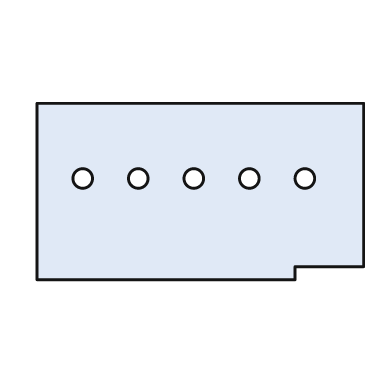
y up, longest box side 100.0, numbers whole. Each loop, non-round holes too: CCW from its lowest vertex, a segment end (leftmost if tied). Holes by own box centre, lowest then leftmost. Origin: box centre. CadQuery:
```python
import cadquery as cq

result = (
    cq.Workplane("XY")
    .moveTo(-50.0, -27.0)
    .lineTo(29.0, -27.0)
    .lineTo(29.0, -23.0)
    .lineTo(50.0, -23.0)
    .lineTo(50.0, 27.0)
    .lineTo(-50.0, 27.0)
    .close()
    .moveTo(-36.0, 4.0)
    .circle(3.0)
    .moveTo(-19.0, 4.0)
    .circle(3.0)
    .moveTo(-2.0, 4.0)
    .circle(3.0)
    .moveTo(15.0, 4.0)
    .circle(3.0)
    .moveTo(32.0, 4.0)
    .circle(3.0)
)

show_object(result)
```